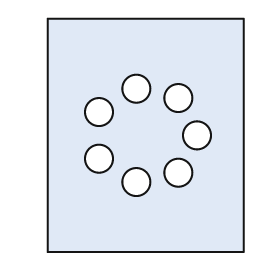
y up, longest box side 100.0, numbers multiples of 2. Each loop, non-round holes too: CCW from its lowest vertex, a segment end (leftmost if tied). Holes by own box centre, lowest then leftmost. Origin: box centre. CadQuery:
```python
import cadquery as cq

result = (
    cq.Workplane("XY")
    .moveTo(-42.0, -50.0)
    .lineTo(42.0, -50.0)
    .lineTo(42.0, 50.0)
    .lineTo(-42.0, 50.0)
    .close()
    .moveTo(-4.0, -20.0)
    .circle(6.0)
    .moveTo(14.0, -16.0)
    .circle(6.0)
    .moveTo(-20.0, -10.0)
    .circle(6.0)
    .moveTo(22.0, 0.0)
    .circle(6.0)
    .moveTo(-20.0, 10.0)
    .circle(6.0)
    .moveTo(14.0, 16.0)
    .circle(6.0)
    .moveTo(-4.0, 20.0)
    .circle(6.0)
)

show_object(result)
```